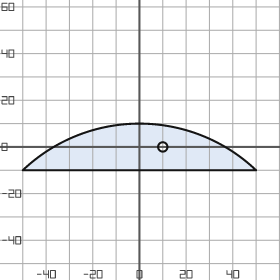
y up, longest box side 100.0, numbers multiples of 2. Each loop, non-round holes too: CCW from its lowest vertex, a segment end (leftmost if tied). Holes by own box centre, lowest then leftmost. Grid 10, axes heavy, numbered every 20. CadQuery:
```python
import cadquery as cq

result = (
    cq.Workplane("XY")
    .moveTo(-50.0, -10.0)
    .lineTo(50.0, -10.0)
    .threePointArc((0.0, 10.0), (-50.0, -10.0))
    .close()
    .moveTo(10.0, 0.0)
    .circle(2.0)
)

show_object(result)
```